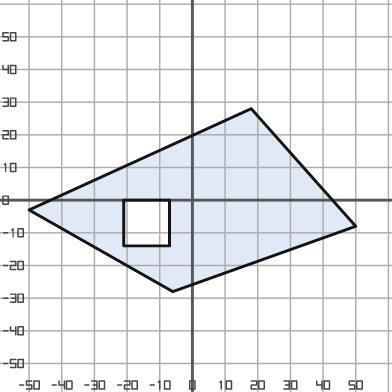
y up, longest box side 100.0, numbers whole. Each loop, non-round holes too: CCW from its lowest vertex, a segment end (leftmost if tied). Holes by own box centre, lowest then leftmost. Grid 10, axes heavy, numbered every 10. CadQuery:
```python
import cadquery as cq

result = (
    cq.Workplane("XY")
    .moveTo(-6.0, -28.0)
    .lineTo(50.0, -8.0)
    .lineTo(18.0, 28.0)
    .lineTo(-50.0, -3.0)
    .close()
    .moveTo(-21.0, -14.0)
    .lineTo(-7.0, -14.0)
    .lineTo(-7.0, 0.0)
    .lineTo(-21.0, 0.0)
    .close()
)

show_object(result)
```